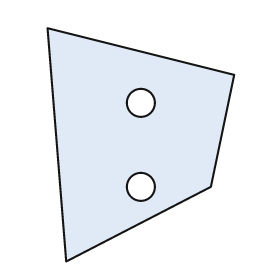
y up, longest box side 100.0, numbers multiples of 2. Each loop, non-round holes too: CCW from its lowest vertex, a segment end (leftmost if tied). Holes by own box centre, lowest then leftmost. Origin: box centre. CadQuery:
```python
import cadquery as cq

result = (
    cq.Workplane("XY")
    .moveTo(-32.0, -50.0)
    .lineTo(30.0, -18.0)
    .lineTo(40.0, 30.0)
    .lineTo(-40.0, 50.0)
    .close()
    .moveTo(0.0, -18.0)
    .circle(6.0)
    .moveTo(0.0, 18.0)
    .circle(6.0)
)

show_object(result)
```